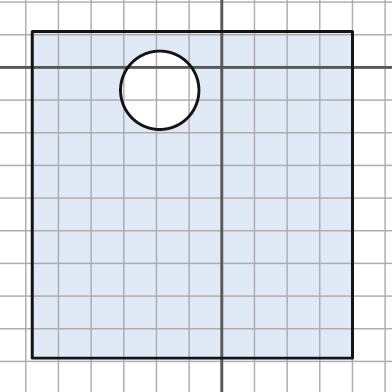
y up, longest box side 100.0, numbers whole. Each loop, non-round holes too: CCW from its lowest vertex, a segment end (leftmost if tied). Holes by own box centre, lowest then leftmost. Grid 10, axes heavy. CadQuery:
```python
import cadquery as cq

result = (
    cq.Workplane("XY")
    .moveTo(-58.0, -89.0)
    .lineTo(40.0, -89.0)
    .lineTo(40.0, 11.0)
    .lineTo(-58.0, 11.0)
    .close()
    .moveTo(-19.0, -7.0)
    .circle(12.0)
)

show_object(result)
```